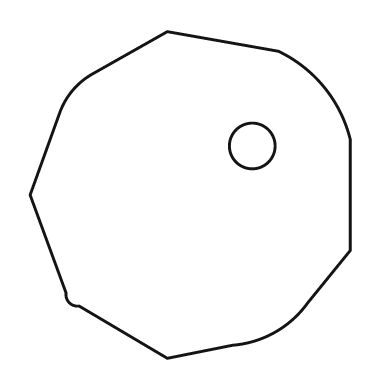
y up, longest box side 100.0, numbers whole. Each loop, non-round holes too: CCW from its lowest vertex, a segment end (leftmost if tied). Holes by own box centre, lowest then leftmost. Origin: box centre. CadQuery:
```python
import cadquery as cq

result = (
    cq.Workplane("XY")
    .moveTo(-7.0, -50.0)
    .lineTo(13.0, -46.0)
    .threePointArc((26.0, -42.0), (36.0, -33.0))
    .lineTo(49.0, -17.0)
    .lineTo(49.0, 17.0)
    .threePointArc((41.0, 33.0), (27.0, 44.0))
    .lineTo(-7.0, 50.0)
    .lineTo(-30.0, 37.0)
    .threePointArc((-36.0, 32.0), (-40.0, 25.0))
    .lineTo(-49.0, 0.0)
    .lineTo(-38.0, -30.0)
    .threePointArc((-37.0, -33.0), (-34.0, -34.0))
    .close()
    .moveTo(19.0, 15.0)
    .circle(7.0)
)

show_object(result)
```